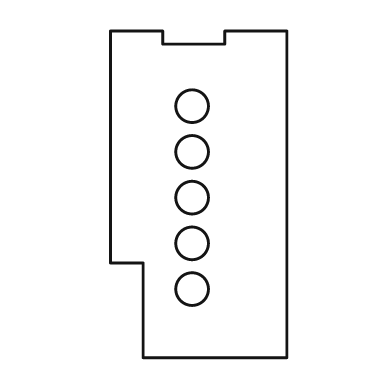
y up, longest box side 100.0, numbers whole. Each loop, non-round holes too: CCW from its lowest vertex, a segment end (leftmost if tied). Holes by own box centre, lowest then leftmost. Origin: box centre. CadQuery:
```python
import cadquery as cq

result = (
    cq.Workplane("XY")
    .moveTo(-17.0, -50.0)
    .lineTo(27.0, -50.0)
    .lineTo(27.0, 50.0)
    .lineTo(8.0, 50.0)
    .lineTo(8.0, 46.0)
    .lineTo(-11.0, 46.0)
    .lineTo(-11.0, 50.0)
    .lineTo(-27.0, 50.0)
    .lineTo(-27.0, -21.0)
    .lineTo(-17.0, -21.0)
    .close()
    .moveTo(-2.0, -29.0)
    .circle(5.0)
    .moveTo(-2.0, -15.0)
    .circle(5.0)
    .moveTo(-2.0, -1.0)
    .circle(5.0)
    .moveTo(-2.0, 13.0)
    .circle(5.0)
    .moveTo(-2.0, 27.0)
    .circle(5.0)
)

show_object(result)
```